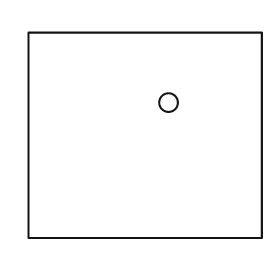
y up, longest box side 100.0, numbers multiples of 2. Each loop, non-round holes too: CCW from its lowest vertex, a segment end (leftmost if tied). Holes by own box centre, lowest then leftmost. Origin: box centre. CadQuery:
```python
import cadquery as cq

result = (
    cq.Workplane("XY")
    .moveTo(-50.0, -44.0)
    .lineTo(50.0, -44.0)
    .lineTo(50.0, 44.0)
    .lineTo(-50.0, 44.0)
    .close()
    .moveTo(10.0, 14.0)
    .circle(4.0)
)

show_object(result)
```